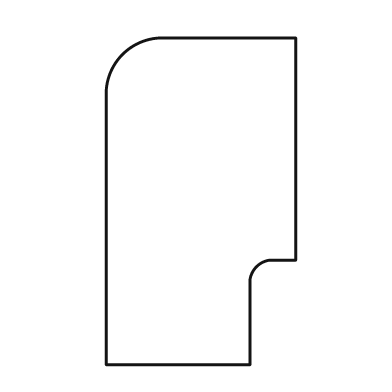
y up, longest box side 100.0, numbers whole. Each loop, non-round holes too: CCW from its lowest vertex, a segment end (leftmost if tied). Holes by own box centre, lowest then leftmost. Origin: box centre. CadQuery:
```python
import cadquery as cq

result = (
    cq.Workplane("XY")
    .moveTo(-29.0, -50.0)
    .lineTo(15.0, -50.0)
    .lineTo(15.0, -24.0)
    .threePointArc((17.0, -20.0), (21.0, -18.0))
    .lineTo(29.0, -18.0)
    .lineTo(29.0, 50.0)
    .lineTo(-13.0, 50.0)
    .threePointArc((-24.0, 45.0), (-29.0, 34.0))
    .close()
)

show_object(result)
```